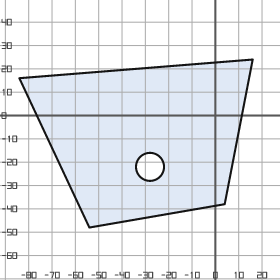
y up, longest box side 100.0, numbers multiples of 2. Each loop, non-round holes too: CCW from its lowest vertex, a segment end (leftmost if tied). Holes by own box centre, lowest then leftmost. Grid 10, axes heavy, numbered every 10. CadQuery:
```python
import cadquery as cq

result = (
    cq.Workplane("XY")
    .moveTo(-54.0, -48.0)
    .lineTo(4.0, -38.0)
    .lineTo(16.0, 24.0)
    .lineTo(-84.0, 16.0)
    .close()
    .moveTo(-28.0, -22.0)
    .circle(6.0)
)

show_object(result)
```